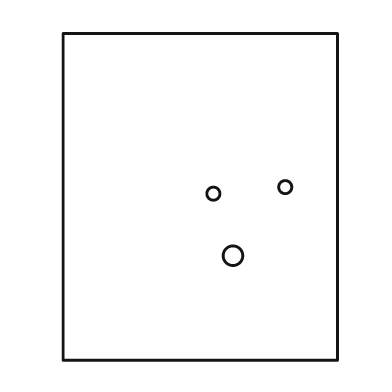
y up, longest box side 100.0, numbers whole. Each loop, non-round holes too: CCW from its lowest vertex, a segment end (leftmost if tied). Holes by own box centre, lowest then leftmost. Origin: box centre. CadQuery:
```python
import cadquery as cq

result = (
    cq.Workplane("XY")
    .moveTo(-42.0, -50.0)
    .lineTo(42.0, -50.0)
    .lineTo(42.0, 50.0)
    .lineTo(-42.0, 50.0)
    .close()
    .moveTo(10.0, -18.0)
    .circle(3.0)
    .moveTo(4.0, 1.0)
    .circle(2.0)
    .moveTo(26.0, 3.0)
    .circle(2.0)
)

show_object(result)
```